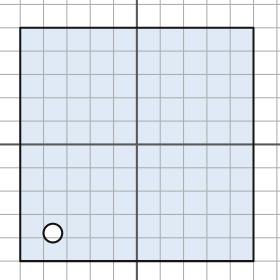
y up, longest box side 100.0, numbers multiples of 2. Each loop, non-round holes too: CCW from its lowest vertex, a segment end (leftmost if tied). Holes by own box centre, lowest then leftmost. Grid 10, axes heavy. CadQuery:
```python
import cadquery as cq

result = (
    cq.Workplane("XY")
    .moveTo(-50.0, -50.0)
    .lineTo(50.0, -50.0)
    .lineTo(50.0, 50.0)
    .lineTo(-50.0, 50.0)
    .close()
    .moveTo(-36.0, -38.0)
    .circle(4.0)
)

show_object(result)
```